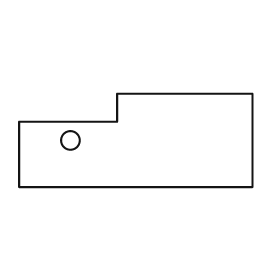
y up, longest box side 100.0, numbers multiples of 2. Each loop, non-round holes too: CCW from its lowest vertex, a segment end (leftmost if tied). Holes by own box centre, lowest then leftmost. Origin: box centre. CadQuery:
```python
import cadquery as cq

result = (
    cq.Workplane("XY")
    .moveTo(-50.0, -20.0)
    .lineTo(50.0, -20.0)
    .lineTo(50.0, 20.0)
    .lineTo(-8.0, 20.0)
    .lineTo(-8.0, 8.0)
    .lineTo(-50.0, 8.0)
    .close()
    .moveTo(-28.0, 0.0)
    .circle(4.0)
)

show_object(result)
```